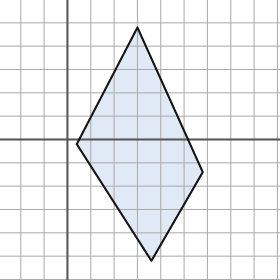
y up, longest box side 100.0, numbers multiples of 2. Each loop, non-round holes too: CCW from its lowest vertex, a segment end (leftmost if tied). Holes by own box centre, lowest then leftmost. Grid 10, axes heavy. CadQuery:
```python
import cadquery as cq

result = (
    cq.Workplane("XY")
    .moveTo(36.0, -52.0)
    .lineTo(58.0, -14.0)
    .lineTo(30.0, 48.0)
    .lineTo(4.0, -2.0)
    .close()
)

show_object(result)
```